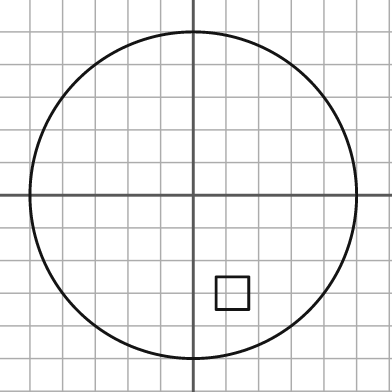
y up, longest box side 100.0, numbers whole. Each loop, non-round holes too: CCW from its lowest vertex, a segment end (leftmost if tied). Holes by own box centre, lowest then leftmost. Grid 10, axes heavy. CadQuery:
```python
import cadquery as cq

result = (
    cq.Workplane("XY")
    .moveTo(0.0, 0.0)
    .circle(50.0)
    .moveTo(7.0, -35.0)
    .lineTo(17.0, -35.0)
    .lineTo(17.0, -25.0)
    .lineTo(7.0, -25.0)
    .close()
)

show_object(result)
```